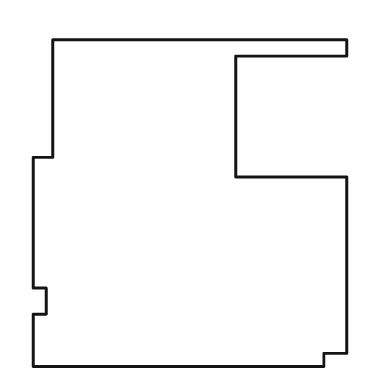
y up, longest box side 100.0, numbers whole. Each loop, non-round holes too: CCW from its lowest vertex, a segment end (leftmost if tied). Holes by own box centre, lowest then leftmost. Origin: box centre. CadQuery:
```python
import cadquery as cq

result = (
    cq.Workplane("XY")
    .moveTo(-48.0, -50.0)
    .lineTo(41.0, -50.0)
    .lineTo(41.0, -46.0)
    .lineTo(48.0, -46.0)
    .lineTo(48.0, 8.0)
    .lineTo(14.0, 8.0)
    .lineTo(14.0, 45.0)
    .lineTo(48.0, 45.0)
    .lineTo(48.0, 50.0)
    .lineTo(-42.0, 50.0)
    .lineTo(-42.0, 14.0)
    .lineTo(-48.0, 14.0)
    .lineTo(-48.0, -26.0)
    .lineTo(-44.0, -26.0)
    .lineTo(-44.0, -34.0)
    .lineTo(-48.0, -34.0)
    .close()
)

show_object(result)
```